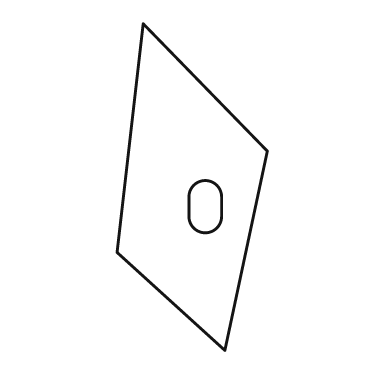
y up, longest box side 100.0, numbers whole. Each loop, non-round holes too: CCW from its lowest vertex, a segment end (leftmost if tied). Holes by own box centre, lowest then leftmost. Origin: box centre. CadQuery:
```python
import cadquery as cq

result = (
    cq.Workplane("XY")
    .moveTo(10.0, -50.0)
    .lineTo(23.0, 11.0)
    .lineTo(-15.0, 50.0)
    .lineTo(-23.0, -20.0)
    .close()
    .moveTo(-1.0, -9.0)
    .threePointArc((4.0, -14.0), (9.0, -9.0))
    .lineTo(9.0, -3.0)
    .threePointArc((4.0, 2.0), (-1.0, -3.0))
    .close()
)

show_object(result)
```